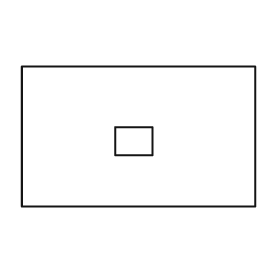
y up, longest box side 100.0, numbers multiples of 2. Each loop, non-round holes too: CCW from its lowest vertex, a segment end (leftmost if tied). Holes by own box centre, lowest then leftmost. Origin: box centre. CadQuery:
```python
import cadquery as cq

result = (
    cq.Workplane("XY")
    .moveTo(-50.0, -30.0)
    .lineTo(50.0, -30.0)
    .lineTo(50.0, 30.0)
    .lineTo(-50.0, 30.0)
    .close()
    .moveTo(-10.0, -8.0)
    .lineTo(6.0, -8.0)
    .lineTo(6.0, 4.0)
    .lineTo(-10.0, 4.0)
    .close()
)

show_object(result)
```